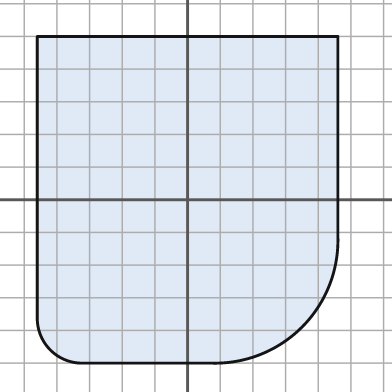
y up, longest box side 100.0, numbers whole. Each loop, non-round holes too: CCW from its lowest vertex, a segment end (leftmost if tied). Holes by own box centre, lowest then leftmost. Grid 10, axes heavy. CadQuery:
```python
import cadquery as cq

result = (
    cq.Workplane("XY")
    .moveTo(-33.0, -50.0)
    .lineTo(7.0, -50.0)
    .threePointArc((35.0, -39.0), (46.0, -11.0))
    .lineTo(46.0, 50.0)
    .lineTo(-46.0, 50.0)
    .lineTo(-46.0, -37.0)
    .threePointArc((-42.0, -46.0), (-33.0, -50.0))
    .close()
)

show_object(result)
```